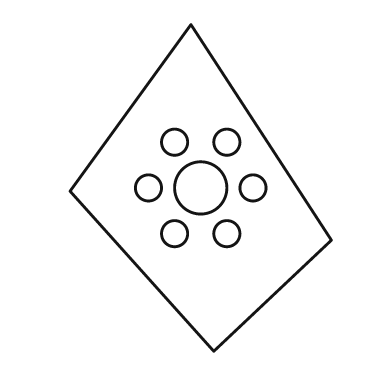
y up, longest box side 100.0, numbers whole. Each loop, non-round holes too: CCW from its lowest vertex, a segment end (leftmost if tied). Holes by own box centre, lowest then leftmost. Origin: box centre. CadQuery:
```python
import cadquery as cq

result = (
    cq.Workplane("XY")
    .moveTo(4.0, -50.0)
    .lineTo(40.0, -16.0)
    .lineTo(-3.0, 50.0)
    .lineTo(-40.0, -1.0)
    .close()
    .moveTo(-8.0, -14.0)
    .circle(4.0)
    .moveTo(8.0, -14.0)
    .circle(4.0)
    .moveTo(-16.0, 0.0)
    .circle(4.0)
    .moveTo(0.0, 0.0)
    .circle(8.0)
    .moveTo(16.0, 0.0)
    .circle(4.0)
    .moveTo(-8.0, 14.0)
    .circle(4.0)
    .moveTo(8.0, 14.0)
    .circle(4.0)
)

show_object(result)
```